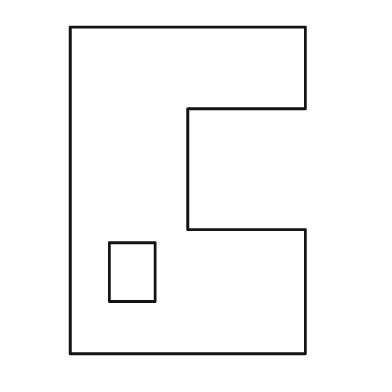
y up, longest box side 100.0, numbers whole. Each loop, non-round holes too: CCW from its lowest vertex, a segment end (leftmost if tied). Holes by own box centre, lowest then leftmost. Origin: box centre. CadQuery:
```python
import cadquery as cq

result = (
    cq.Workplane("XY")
    .moveTo(-36.0, -50.0)
    .lineTo(36.0, -50.0)
    .lineTo(36.0, -12.0)
    .lineTo(0.0, -12.0)
    .lineTo(0.0, 25.0)
    .lineTo(36.0, 25.0)
    .lineTo(36.0, 50.0)
    .lineTo(-36.0, 50.0)
    .close()
    .moveTo(-24.0, -34.0)
    .lineTo(-10.0, -34.0)
    .lineTo(-10.0, -16.0)
    .lineTo(-24.0, -16.0)
    .close()
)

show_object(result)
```